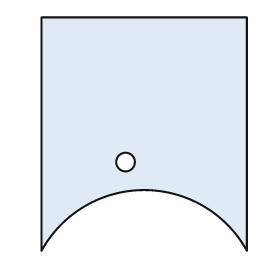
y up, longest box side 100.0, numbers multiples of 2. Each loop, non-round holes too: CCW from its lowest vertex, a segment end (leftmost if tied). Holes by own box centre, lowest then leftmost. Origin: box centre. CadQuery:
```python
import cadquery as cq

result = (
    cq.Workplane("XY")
    .moveTo(-44.0, -50.0)
    .threePointArc((0.0, -24.0), (44.0, -50.0))
    .lineTo(44.0, 50.0)
    .lineTo(-44.0, 50.0)
    .close()
    .moveTo(-8.0, -12.0)
    .circle(4.0)
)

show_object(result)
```